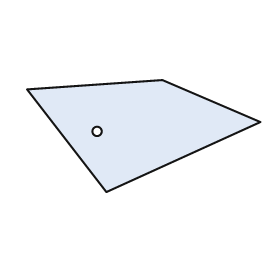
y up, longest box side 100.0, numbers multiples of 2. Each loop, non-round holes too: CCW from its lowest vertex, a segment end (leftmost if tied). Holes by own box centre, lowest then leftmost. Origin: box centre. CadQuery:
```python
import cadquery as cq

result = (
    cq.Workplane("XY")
    .moveTo(-16.0, -24.0)
    .lineTo(50.0, 6.0)
    .lineTo(8.0, 24.0)
    .lineTo(-50.0, 20.0)
    .close()
    .moveTo(-20.0, 2.0)
    .circle(2.0)
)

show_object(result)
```